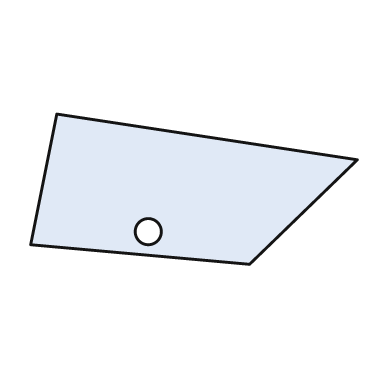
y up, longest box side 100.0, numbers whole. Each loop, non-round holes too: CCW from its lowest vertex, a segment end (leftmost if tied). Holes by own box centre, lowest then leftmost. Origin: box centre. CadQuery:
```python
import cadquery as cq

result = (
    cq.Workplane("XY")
    .moveTo(17.0, -23.0)
    .lineTo(50.0, 9.0)
    .lineTo(-42.0, 23.0)
    .lineTo(-50.0, -17.0)
    .close()
    .moveTo(-14.0, -13.0)
    .circle(4.0)
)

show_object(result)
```